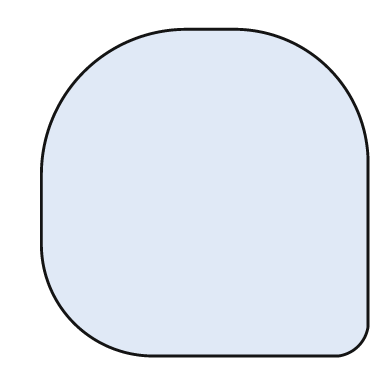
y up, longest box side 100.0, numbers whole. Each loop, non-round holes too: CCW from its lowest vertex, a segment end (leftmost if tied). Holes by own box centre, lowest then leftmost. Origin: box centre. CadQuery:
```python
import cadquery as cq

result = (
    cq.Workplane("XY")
    .moveTo(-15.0, -50.0)
    .lineTo(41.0, -50.0)
    .threePointArc((47.0, -47.0), (50.0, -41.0))
    .lineTo(50.0, 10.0)
    .threePointArc((38.0, 38.0), (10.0, 50.0))
    .lineTo(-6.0, 50.0)
    .threePointArc((-37.0, 37.0), (-50.0, 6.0))
    .lineTo(-50.0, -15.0)
    .threePointArc((-40.0, -40.0), (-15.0, -50.0))
    .close()
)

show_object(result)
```